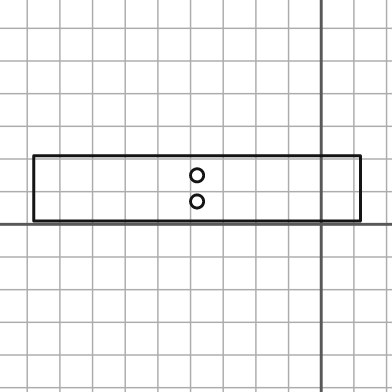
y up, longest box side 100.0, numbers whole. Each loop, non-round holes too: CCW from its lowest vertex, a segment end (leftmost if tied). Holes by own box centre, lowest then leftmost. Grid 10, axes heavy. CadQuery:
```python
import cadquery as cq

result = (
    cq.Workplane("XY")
    .moveTo(-88.0, 1.0)
    .lineTo(12.0, 1.0)
    .lineTo(12.0, 21.0)
    .lineTo(-88.0, 21.0)
    .close()
    .moveTo(-38.0, 7.0)
    .circle(2.0)
    .moveTo(-38.0, 15.0)
    .circle(2.0)
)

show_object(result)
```